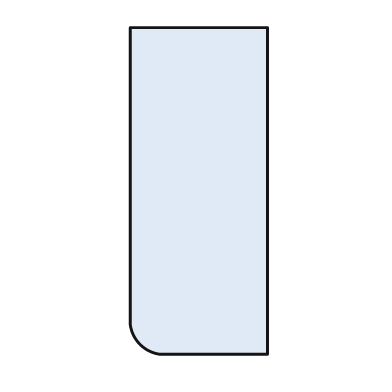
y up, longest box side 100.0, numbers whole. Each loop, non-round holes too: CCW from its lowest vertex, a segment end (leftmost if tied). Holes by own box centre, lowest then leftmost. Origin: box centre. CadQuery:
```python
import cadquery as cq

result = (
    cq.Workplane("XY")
    .moveTo(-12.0, -50.0)
    .lineTo(21.0, -50.0)
    .lineTo(21.0, 50.0)
    .lineTo(-21.0, 50.0)
    .lineTo(-21.0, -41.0)
    .threePointArc((-18.0, -47.0), (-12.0, -50.0))
    .close()
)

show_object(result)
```